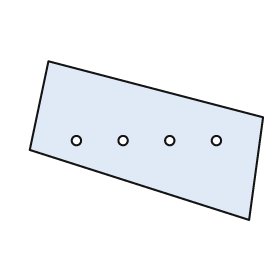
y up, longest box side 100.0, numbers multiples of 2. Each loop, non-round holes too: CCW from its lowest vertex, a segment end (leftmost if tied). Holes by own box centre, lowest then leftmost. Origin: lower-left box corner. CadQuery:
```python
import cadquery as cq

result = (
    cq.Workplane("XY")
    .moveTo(94.0, 0.0)
    .lineTo(100.0, 44.0)
    .lineTo(8.0, 68.0)
    .lineTo(0.0, 30.0)
    .close()
    .moveTo(20.0, 34.0)
    .circle(2.0)
    .moveTo(40.0, 34.0)
    .circle(2.0)
    .moveTo(60.0, 34.0)
    .circle(2.0)
    .moveTo(80.0, 34.0)
    .circle(2.0)
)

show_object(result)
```